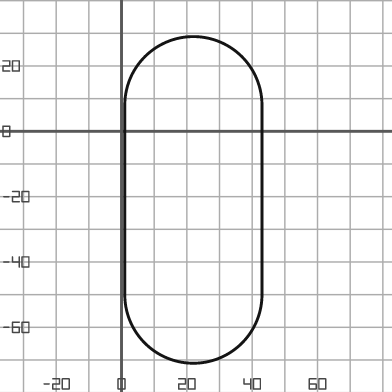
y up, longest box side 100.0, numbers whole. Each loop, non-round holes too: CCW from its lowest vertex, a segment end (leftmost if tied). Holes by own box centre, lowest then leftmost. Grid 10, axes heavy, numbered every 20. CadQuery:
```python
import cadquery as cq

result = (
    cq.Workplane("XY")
    .moveTo(1.0, -50.0)
    .threePointArc((22.0, -71.0), (43.0, -50.0))
    .lineTo(43.0, 8.0)
    .threePointArc((22.0, 29.0), (1.0, 8.0))
    .close()
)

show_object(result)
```